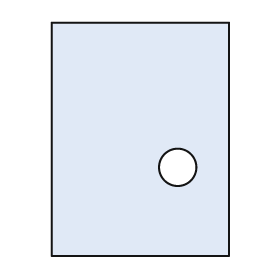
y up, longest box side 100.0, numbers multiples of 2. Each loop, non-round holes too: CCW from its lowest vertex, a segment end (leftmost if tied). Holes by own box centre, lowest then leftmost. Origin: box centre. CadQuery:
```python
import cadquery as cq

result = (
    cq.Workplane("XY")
    .moveTo(-38.0, -50.0)
    .lineTo(38.0, -50.0)
    .lineTo(38.0, 50.0)
    .lineTo(-38.0, 50.0)
    .close()
    .moveTo(16.0, -12.0)
    .circle(8.0)
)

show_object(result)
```